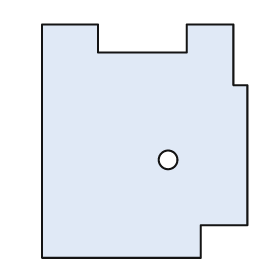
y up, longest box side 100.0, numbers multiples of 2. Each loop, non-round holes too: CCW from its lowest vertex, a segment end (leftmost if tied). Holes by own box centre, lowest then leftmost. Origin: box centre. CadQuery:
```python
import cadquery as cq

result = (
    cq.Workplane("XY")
    .moveTo(-44.0, -50.0)
    .lineTo(24.0, -50.0)
    .lineTo(24.0, -36.0)
    .lineTo(44.0, -36.0)
    .lineTo(44.0, 24.0)
    .lineTo(38.0, 24.0)
    .lineTo(38.0, 50.0)
    .lineTo(18.0, 50.0)
    .lineTo(18.0, 38.0)
    .lineTo(-20.0, 38.0)
    .lineTo(-20.0, 50.0)
    .lineTo(-44.0, 50.0)
    .close()
    .moveTo(10.0, -8.0)
    .circle(4.0)
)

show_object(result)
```